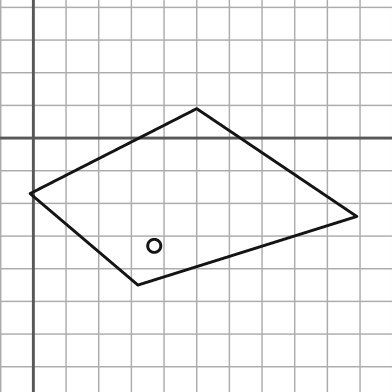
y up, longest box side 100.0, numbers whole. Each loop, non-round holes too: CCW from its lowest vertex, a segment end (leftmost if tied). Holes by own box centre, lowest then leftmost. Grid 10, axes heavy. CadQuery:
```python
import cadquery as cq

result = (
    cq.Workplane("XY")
    .moveTo(32.0, -45.0)
    .lineTo(99.0, -24.0)
    .lineTo(50.0, 9.0)
    .lineTo(-1.0, -17.0)
    .close()
    .moveTo(37.0, -33.0)
    .circle(2.0)
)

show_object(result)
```